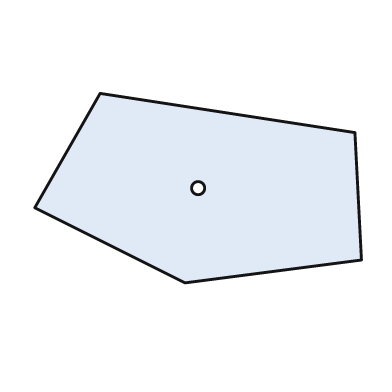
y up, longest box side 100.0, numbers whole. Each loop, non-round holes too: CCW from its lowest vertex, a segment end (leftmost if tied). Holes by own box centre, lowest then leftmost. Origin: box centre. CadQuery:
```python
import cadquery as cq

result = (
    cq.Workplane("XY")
    .moveTo(-4.0, -29.0)
    .lineTo(50.0, -22.0)
    .lineTo(48.0, 17.0)
    .lineTo(-30.0, 29.0)
    .lineTo(-50.0, -6.0)
    .close()
    .moveTo(0.0, 0.0)
    .circle(2.0)
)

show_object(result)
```